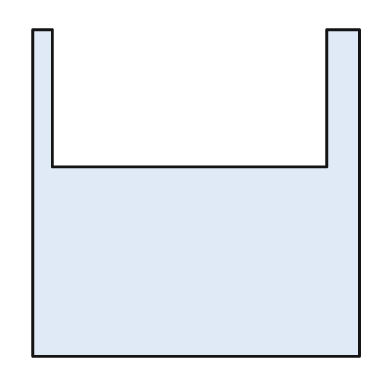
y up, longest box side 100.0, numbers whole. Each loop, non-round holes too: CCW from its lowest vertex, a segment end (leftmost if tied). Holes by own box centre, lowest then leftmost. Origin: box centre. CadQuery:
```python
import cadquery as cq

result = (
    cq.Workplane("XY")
    .moveTo(-50.0, -50.0)
    .lineTo(50.0, -50.0)
    .lineTo(50.0, 50.0)
    .lineTo(40.0, 50.0)
    .lineTo(40.0, 8.0)
    .lineTo(-44.0, 8.0)
    .lineTo(-44.0, 50.0)
    .lineTo(-50.0, 50.0)
    .close()
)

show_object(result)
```